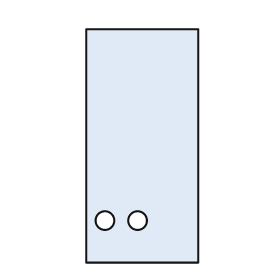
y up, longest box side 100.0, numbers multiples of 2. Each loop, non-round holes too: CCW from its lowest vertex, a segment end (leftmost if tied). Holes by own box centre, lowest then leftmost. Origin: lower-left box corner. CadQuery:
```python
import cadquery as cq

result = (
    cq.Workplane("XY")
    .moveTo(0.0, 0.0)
    .lineTo(48.0, 0.0)
    .lineTo(48.0, 100.0)
    .lineTo(0.0, 100.0)
    .close()
    .moveTo(8.0, 18.0)
    .circle(4.0)
    .moveTo(22.0, 18.0)
    .circle(4.0)
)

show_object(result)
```